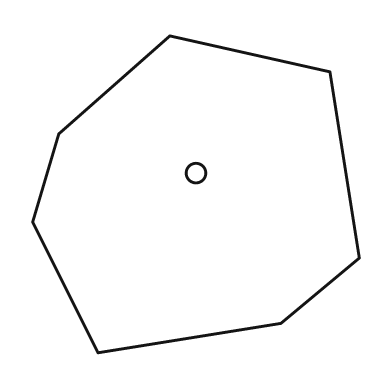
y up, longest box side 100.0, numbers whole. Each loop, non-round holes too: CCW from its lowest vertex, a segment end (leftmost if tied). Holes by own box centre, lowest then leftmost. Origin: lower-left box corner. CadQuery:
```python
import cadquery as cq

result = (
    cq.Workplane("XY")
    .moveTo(20.0, 0.0)
    .lineTo(76.0, 9.0)
    .lineTo(100.0, 29.0)
    .lineTo(91.0, 86.0)
    .lineTo(42.0, 97.0)
    .lineTo(8.0, 67.0)
    .lineTo(0.0, 40.0)
    .close()
    .moveTo(50.0, 55.0)
    .circle(3.0)
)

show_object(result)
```